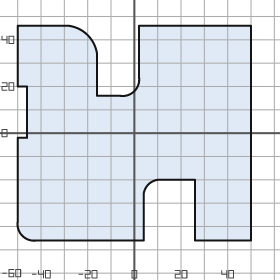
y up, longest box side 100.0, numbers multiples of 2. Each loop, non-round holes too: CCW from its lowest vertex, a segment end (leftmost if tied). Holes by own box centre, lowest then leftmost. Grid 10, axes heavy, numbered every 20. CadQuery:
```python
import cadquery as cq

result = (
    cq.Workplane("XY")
    .moveTo(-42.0, -46.0)
    .lineTo(4.0, -46.0)
    .lineTo(4.0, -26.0)
    .threePointArc((6.0, -22.0), (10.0, -20.0))
    .lineTo(26.0, -20.0)
    .lineTo(26.0, -46.0)
    .lineTo(50.0, -46.0)
    .lineTo(50.0, 46.0)
    .lineTo(2.0, 46.0)
    .lineTo(2.0, 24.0)
    .threePointArc((0.0, 18.0), (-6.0, 16.0))
    .lineTo(-16.0, 16.0)
    .lineTo(-16.0, 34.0)
    .threePointArc((-20.0, 42.0), (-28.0, 46.0))
    .lineTo(-50.0, 46.0)
    .lineTo(-50.0, 20.0)
    .lineTo(-46.0, 20.0)
    .lineTo(-46.0, -2.0)
    .lineTo(-50.0, -2.0)
    .lineTo(-50.0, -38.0)
    .threePointArc((-48.0, -44.0), (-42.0, -46.0))
    .close()
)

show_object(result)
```